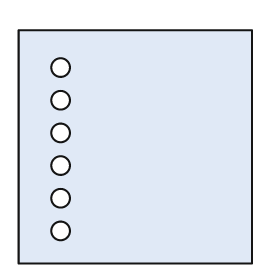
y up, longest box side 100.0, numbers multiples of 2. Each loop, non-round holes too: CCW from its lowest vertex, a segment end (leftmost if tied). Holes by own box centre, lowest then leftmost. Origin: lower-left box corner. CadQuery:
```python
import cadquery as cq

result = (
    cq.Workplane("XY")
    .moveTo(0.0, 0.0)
    .lineTo(100.0, 0.0)
    .lineTo(100.0, 100.0)
    .lineTo(0.0, 100.0)
    .close()
    .moveTo(18.0, 14.0)
    .circle(4.0)
    .moveTo(18.0, 28.0)
    .circle(4.0)
    .moveTo(18.0, 42.0)
    .circle(4.0)
    .moveTo(18.0, 56.0)
    .circle(4.0)
    .moveTo(18.0, 70.0)
    .circle(4.0)
    .moveTo(18.0, 84.0)
    .circle(4.0)
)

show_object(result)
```